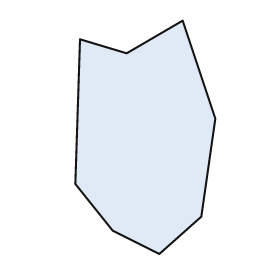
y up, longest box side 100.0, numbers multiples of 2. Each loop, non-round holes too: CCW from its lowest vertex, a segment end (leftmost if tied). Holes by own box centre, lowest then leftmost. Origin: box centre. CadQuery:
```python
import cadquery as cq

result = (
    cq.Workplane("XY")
    .moveTo(6.0, -50.0)
    .lineTo(24.0, -34.0)
    .lineTo(30.0, 8.0)
    .lineTo(16.0, 50.0)
    .lineTo(-8.0, 36.0)
    .lineTo(-28.0, 42.0)
    .lineTo(-30.0, -20.0)
    .lineTo(-14.0, -40.0)
    .close()
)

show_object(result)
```